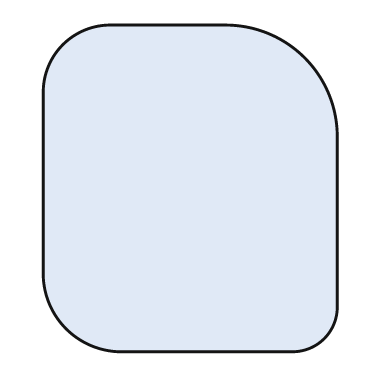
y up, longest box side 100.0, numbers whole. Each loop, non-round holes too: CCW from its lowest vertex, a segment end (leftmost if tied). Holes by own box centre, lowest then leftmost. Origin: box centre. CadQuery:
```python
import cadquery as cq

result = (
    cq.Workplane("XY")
    .moveTo(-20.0, -50.0)
    .lineTo(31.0, -50.0)
    .threePointArc((41.0, -46.0), (45.0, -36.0))
    .lineTo(45.0, 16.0)
    .threePointArc((35.0, 40.0), (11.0, 50.0))
    .lineTo(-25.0, 50.0)
    .threePointArc((-39.0, 44.0), (-45.0, 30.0))
    .lineTo(-45.0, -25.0)
    .threePointArc((-38.0, -43.0), (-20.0, -50.0))
    .close()
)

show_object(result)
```